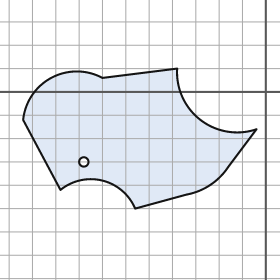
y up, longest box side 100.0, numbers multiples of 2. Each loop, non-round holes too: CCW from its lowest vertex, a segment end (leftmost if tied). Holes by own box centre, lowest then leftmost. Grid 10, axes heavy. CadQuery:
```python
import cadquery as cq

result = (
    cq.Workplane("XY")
    .moveTo(-56.0, -50.0)
    .lineTo(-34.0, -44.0)
    .threePointArc((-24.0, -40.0), (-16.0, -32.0))
    .lineTo(-4.0, -16.0)
    .threePointArc((-28.0, -12.0), (-38.0, 10.0))
    .lineTo(-70.0, 6.0)
    .threePointArc((-92.0, 6.0), (-104.0, -12.0))
    .lineTo(-88.0, -42.0)
    .threePointArc((-70.0, -38.0), (-56.0, -50.0))
    .close()
    .moveTo(-78.0, -30.0)
    .circle(2.0)
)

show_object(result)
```